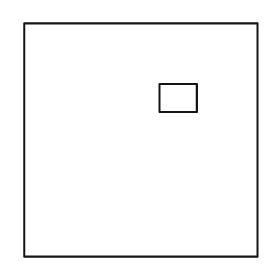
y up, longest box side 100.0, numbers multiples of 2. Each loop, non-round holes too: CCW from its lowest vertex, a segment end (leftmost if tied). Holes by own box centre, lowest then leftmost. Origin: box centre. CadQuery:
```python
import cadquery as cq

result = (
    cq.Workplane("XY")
    .moveTo(-50.0, -50.0)
    .lineTo(50.0, -50.0)
    .lineTo(50.0, 50.0)
    .lineTo(-50.0, 50.0)
    .close()
    .moveTo(8.0, 12.0)
    .lineTo(24.0, 12.0)
    .lineTo(24.0, 24.0)
    .lineTo(8.0, 24.0)
    .close()
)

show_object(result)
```